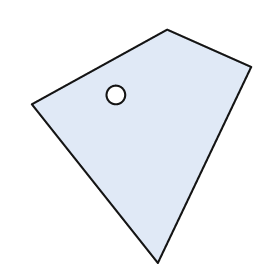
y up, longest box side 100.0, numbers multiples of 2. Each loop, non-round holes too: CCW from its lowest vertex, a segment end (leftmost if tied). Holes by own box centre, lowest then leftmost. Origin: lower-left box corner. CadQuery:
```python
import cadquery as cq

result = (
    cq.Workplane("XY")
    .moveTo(54.0, 0.0)
    .lineTo(94.0, 84.0)
    .lineTo(58.0, 100.0)
    .lineTo(0.0, 68.0)
    .close()
    .moveTo(36.0, 72.0)
    .circle(4.0)
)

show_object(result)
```